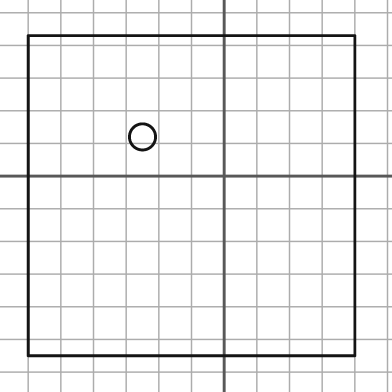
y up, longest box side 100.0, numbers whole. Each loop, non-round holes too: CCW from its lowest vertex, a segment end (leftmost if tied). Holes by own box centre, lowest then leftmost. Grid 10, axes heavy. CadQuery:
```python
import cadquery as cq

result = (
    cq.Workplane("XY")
    .moveTo(-60.0, -55.0)
    .lineTo(40.0, -55.0)
    .lineTo(40.0, 43.0)
    .lineTo(-60.0, 43.0)
    .close()
    .moveTo(-25.0, 12.0)
    .circle(4.0)
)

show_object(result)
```